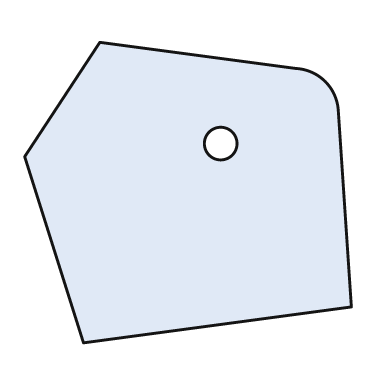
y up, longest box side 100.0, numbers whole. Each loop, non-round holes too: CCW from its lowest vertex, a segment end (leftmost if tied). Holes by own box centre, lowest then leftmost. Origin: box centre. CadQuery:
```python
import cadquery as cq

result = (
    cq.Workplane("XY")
    .moveTo(-32.0, -46.0)
    .lineTo(50.0, -35.0)
    .lineTo(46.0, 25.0)
    .threePointArc((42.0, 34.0), (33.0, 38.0))
    .lineTo(-27.0, 46.0)
    .lineTo(-50.0, 11.0)
    .close()
    .moveTo(10.0, 15.0)
    .circle(5.0)
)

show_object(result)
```